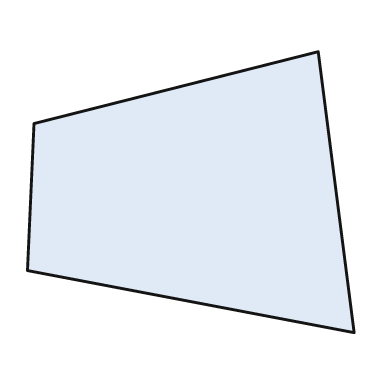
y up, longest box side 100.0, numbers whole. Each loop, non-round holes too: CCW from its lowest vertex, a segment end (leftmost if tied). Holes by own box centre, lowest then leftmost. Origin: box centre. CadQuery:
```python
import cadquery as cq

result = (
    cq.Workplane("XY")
    .moveTo(50.0, -43.0)
    .lineTo(39.0, 43.0)
    .lineTo(-48.0, 21.0)
    .lineTo(-50.0, -24.0)
    .close()
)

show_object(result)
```